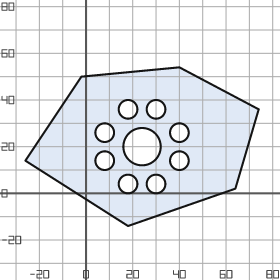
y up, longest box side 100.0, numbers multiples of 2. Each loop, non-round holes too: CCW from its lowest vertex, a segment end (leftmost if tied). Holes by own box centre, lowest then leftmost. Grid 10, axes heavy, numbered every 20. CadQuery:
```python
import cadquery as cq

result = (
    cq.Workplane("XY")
    .moveTo(18.0, -14.0)
    .lineTo(64.0, 2.0)
    .lineTo(74.0, 36.0)
    .lineTo(40.0, 54.0)
    .lineTo(-2.0, 50.0)
    .lineTo(-26.0, 14.0)
    .close()
    .moveTo(18.0, 4.0)
    .circle(4.0)
    .moveTo(30.0, 4.0)
    .circle(4.0)
    .moveTo(8.0, 14.0)
    .circle(4.0)
    .moveTo(40.0, 14.0)
    .circle(4.0)
    .moveTo(24.0, 20.0)
    .circle(8.0)
    .moveTo(8.0, 26.0)
    .circle(4.0)
    .moveTo(40.0, 26.0)
    .circle(4.0)
    .moveTo(18.0, 36.0)
    .circle(4.0)
    .moveTo(30.0, 36.0)
    .circle(4.0)
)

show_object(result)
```